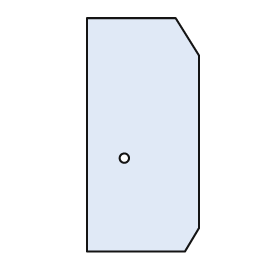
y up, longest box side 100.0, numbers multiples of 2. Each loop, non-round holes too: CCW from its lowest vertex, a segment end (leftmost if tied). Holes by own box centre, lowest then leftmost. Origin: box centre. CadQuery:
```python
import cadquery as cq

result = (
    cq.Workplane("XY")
    .moveTo(-24.0, -50.0)
    .lineTo(18.0, -50.0)
    .lineTo(24.0, -40.0)
    .lineTo(24.0, 34.0)
    .lineTo(14.0, 50.0)
    .lineTo(-24.0, 50.0)
    .close()
    .moveTo(-8.0, -10.0)
    .circle(2.0)
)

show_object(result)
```